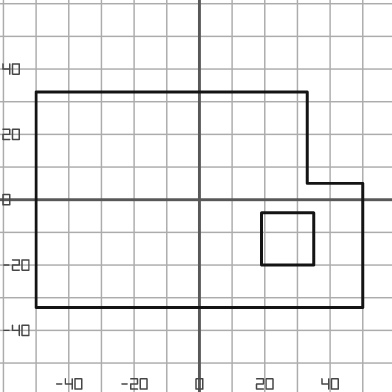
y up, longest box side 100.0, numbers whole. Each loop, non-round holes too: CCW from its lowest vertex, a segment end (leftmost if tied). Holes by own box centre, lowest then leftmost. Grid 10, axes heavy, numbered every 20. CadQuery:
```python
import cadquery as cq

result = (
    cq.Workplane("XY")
    .moveTo(-50.0, -33.0)
    .lineTo(50.0, -33.0)
    .lineTo(50.0, 5.0)
    .lineTo(33.0, 5.0)
    .lineTo(33.0, 33.0)
    .lineTo(-50.0, 33.0)
    .close()
    .moveTo(19.0, -20.0)
    .lineTo(35.0, -20.0)
    .lineTo(35.0, -4.0)
    .lineTo(19.0, -4.0)
    .close()
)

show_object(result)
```